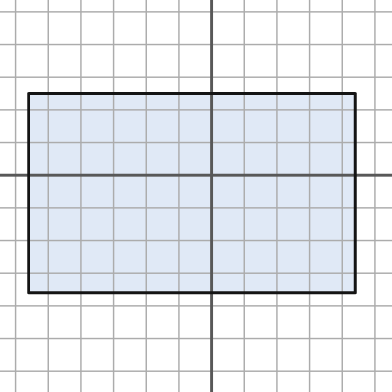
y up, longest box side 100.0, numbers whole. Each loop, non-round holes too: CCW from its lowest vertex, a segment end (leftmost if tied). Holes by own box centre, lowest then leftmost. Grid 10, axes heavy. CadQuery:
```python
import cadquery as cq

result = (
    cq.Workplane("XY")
    .moveTo(-56.0, -36.0)
    .lineTo(44.0, -36.0)
    .lineTo(44.0, 25.0)
    .lineTo(-56.0, 25.0)
    .close()
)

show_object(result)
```